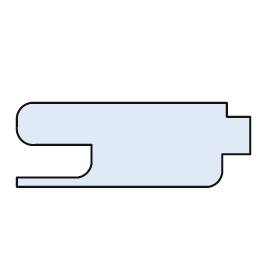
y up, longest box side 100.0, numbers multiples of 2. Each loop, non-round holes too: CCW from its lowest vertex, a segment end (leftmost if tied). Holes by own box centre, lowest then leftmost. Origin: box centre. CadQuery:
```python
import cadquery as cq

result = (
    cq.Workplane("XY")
    .moveTo(-50.0, -18.0)
    .lineTo(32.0, -18.0)
    .threePointArc((36.0, -16.0), (38.0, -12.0))
    .lineTo(38.0, -4.0)
    .lineTo(50.0, -4.0)
    .lineTo(50.0, 12.0)
    .lineTo(40.0, 12.0)
    .lineTo(40.0, 18.0)
    .lineTo(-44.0, 18.0)
    .threePointArc((-48.0, 16.0), (-50.0, 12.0))
    .lineTo(-50.0, 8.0)
    .threePointArc((-48.0, 2.0), (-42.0, 0.0))
    .lineTo(-18.0, 0.0)
    .lineTo(-18.0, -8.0)
    .threePointArc((-20.0, -12.0), (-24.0, -14.0))
    .lineTo(-50.0, -14.0)
    .close()
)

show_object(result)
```